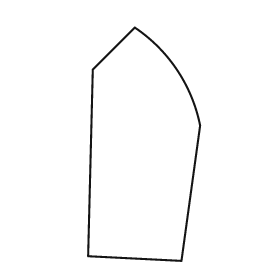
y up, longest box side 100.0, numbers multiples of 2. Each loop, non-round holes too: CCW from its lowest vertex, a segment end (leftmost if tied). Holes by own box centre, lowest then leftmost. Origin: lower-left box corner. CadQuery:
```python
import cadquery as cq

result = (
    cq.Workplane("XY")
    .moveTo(40.0, 0.0)
    .lineTo(48.0, 58.0)
    .threePointArc((38.0, 82.0), (20.0, 100.0))
    .lineTo(2.0, 82.0)
    .lineTo(0.0, 2.0)
    .close()
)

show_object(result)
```